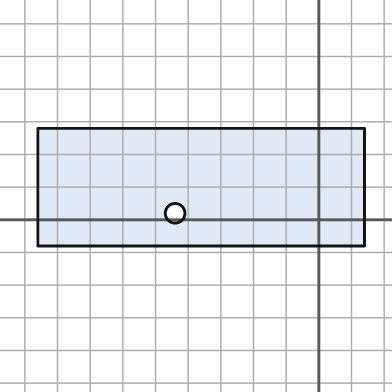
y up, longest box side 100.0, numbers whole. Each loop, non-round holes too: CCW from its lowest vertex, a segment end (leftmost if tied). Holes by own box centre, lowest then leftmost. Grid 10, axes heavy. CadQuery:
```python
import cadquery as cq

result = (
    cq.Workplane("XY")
    .moveTo(-86.0, -8.0)
    .lineTo(14.0, -8.0)
    .lineTo(14.0, 28.0)
    .lineTo(-86.0, 28.0)
    .close()
    .moveTo(-44.0, 2.0)
    .circle(3.0)
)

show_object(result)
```